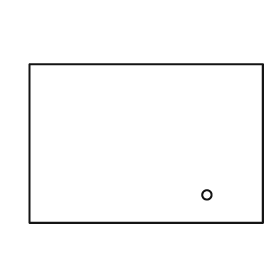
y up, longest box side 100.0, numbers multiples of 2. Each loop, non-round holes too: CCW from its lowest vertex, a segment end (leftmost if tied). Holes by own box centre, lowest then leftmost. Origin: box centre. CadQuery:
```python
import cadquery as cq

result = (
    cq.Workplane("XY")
    .moveTo(-50.0, -34.0)
    .lineTo(50.0, -34.0)
    .lineTo(50.0, 34.0)
    .lineTo(-50.0, 34.0)
    .close()
    .moveTo(26.0, -22.0)
    .circle(2.0)
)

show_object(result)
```